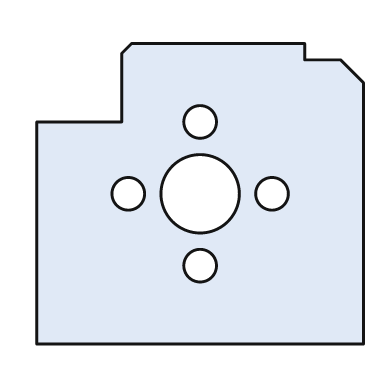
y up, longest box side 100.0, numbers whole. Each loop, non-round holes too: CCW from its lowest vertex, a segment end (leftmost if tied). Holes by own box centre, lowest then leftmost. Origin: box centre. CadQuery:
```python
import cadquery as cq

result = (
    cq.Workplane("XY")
    .moveTo(-50.0, -46.0)
    .lineTo(50.0, -46.0)
    .lineTo(50.0, 34.0)
    .lineTo(43.0, 41.0)
    .lineTo(32.0, 41.0)
    .lineTo(32.0, 46.0)
    .lineTo(-21.0, 46.0)
    .lineTo(-24.0, 43.0)
    .lineTo(-24.0, 22.0)
    .lineTo(-50.0, 22.0)
    .close()
    .moveTo(0.0, -22.0)
    .circle(5.0)
    .moveTo(-22.0, 0.0)
    .circle(5.0)
    .moveTo(0.0, 0.0)
    .circle(12.0)
    .moveTo(22.0, 0.0)
    .circle(5.0)
    .moveTo(0.0, 22.0)
    .circle(5.0)
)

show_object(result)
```